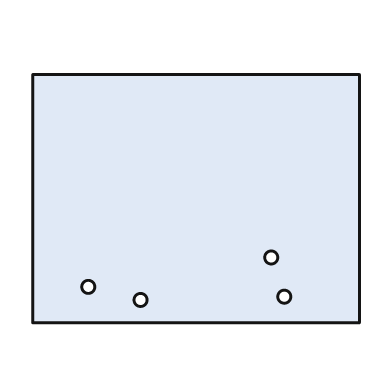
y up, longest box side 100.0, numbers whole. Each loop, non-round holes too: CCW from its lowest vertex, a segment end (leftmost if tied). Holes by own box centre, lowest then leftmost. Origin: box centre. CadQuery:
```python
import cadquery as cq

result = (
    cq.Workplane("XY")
    .moveTo(-50.0, -38.0)
    .lineTo(50.0, -38.0)
    .lineTo(50.0, 38.0)
    .lineTo(-50.0, 38.0)
    .close()
    .moveTo(-17.0, -31.0)
    .circle(2.0)
    .moveTo(27.0, -30.0)
    .circle(2.0)
    .moveTo(-33.0, -27.0)
    .circle(2.0)
    .moveTo(23.0, -18.0)
    .circle(2.0)
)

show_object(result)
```